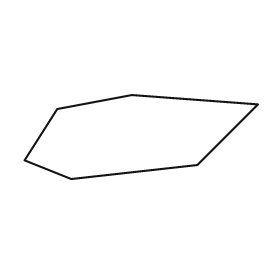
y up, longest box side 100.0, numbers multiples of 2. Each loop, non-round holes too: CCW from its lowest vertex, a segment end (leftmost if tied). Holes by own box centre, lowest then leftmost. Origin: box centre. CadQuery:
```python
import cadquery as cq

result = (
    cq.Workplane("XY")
    .moveTo(-30.0, -18.0)
    .lineTo(24.0, -12.0)
    .lineTo(50.0, 14.0)
    .lineTo(-4.0, 18.0)
    .lineTo(-36.0, 12.0)
    .lineTo(-50.0, -10.0)
    .close()
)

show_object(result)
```